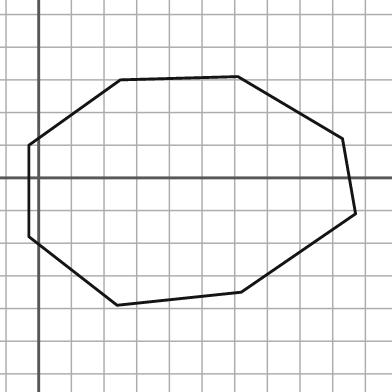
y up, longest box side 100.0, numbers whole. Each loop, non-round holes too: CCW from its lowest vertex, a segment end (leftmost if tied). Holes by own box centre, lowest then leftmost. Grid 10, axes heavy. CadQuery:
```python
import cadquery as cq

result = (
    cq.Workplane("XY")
    .moveTo(24.0, -39.0)
    .lineTo(62.0, -35.0)
    .lineTo(97.0, -11.0)
    .lineTo(93.0, 12.0)
    .lineTo(61.0, 31.0)
    .lineTo(25.0, 30.0)
    .lineTo(-3.0, 10.0)
    .lineTo(-3.0, -18.0)
    .close()
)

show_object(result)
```